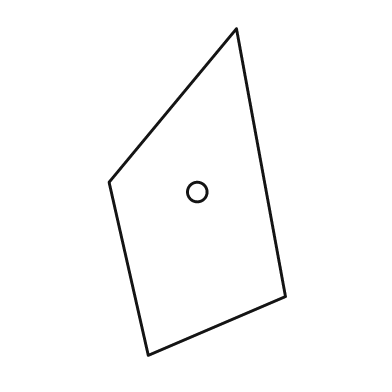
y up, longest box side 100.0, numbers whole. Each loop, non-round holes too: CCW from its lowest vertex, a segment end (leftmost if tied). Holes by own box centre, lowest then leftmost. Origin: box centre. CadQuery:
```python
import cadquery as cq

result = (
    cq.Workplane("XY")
    .moveTo(-15.0, -50.0)
    .lineTo(27.0, -32.0)
    .lineTo(12.0, 50.0)
    .lineTo(-27.0, 3.0)
    .close()
    .moveTo(0.0, 0.0)
    .circle(3.0)
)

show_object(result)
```